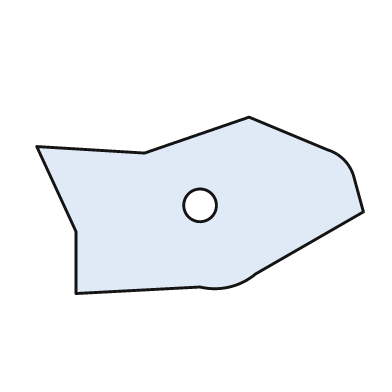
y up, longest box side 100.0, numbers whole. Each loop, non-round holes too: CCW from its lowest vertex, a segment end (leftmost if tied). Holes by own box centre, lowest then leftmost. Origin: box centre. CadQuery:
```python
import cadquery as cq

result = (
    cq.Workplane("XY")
    .moveTo(-38.0, -27.0)
    .lineTo(0.0, -25.0)
    .threePointArc((9.0, -25.0), (17.0, -21.0))
    .lineTo(50.0, -2.0)
    .lineTo(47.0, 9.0)
    .threePointArc((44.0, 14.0), (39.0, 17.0))
    .lineTo(15.0, 27.0)
    .lineTo(-17.0, 16.0)
    .lineTo(-50.0, 18.0)
    .lineTo(-38.0, -8.0)
    .close()
    .moveTo(0.0, 0.0)
    .circle(5.0)
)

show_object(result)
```